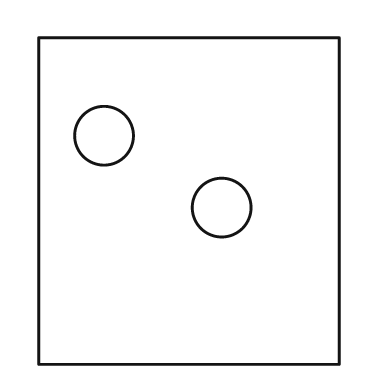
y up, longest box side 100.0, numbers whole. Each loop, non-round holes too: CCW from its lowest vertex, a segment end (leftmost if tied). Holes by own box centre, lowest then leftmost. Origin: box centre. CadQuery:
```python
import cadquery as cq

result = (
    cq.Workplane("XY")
    .moveTo(-46.0, -50.0)
    .lineTo(46.0, -50.0)
    .lineTo(46.0, 50.0)
    .lineTo(-46.0, 50.0)
    .close()
    .moveTo(10.0, -2.0)
    .circle(9.0)
    .moveTo(-26.0, 20.0)
    .circle(9.0)
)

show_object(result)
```